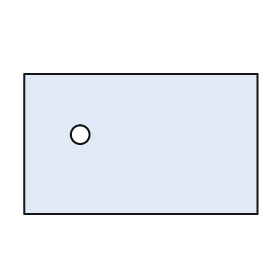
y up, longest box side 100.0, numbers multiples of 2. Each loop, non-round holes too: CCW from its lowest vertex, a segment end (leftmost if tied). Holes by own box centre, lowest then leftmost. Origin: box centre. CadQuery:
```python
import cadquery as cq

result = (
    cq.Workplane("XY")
    .moveTo(-50.0, -30.0)
    .lineTo(50.0, -30.0)
    .lineTo(50.0, 30.0)
    .lineTo(-50.0, 30.0)
    .close()
    .moveTo(-26.0, 4.0)
    .circle(4.0)
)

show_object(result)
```